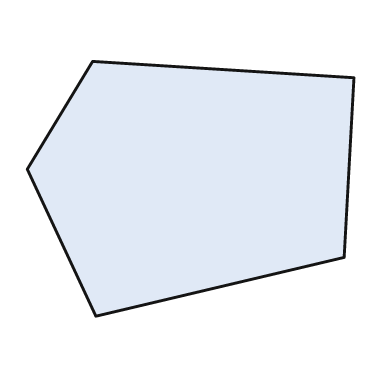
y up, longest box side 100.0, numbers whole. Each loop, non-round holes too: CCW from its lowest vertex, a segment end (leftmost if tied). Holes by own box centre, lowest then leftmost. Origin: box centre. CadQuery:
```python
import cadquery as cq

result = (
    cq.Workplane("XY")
    .moveTo(-29.0, -39.0)
    .lineTo(47.0, -21.0)
    .lineTo(50.0, 34.0)
    .lineTo(-30.0, 39.0)
    .lineTo(-50.0, 6.0)
    .close()
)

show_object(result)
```